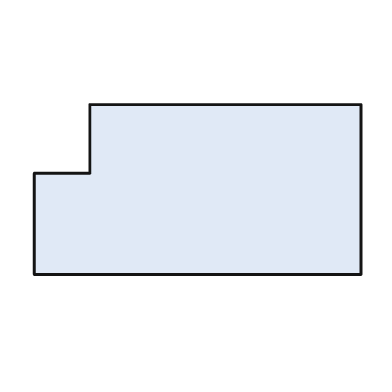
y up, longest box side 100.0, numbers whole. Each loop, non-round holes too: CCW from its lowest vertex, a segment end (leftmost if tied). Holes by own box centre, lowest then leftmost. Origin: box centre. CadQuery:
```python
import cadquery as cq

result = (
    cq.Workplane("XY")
    .moveTo(-50.0, -26.0)
    .lineTo(50.0, -26.0)
    .lineTo(50.0, 26.0)
    .lineTo(-33.0, 26.0)
    .lineTo(-33.0, 5.0)
    .lineTo(-50.0, 5.0)
    .close()
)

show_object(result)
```